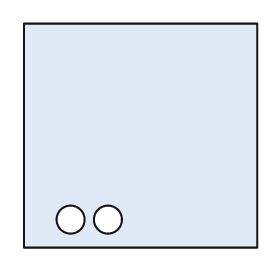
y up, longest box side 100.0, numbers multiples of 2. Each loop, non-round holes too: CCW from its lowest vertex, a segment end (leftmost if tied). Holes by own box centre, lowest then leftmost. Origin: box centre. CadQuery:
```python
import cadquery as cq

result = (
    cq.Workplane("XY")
    .moveTo(-50.0, -48.0)
    .lineTo(50.0, -48.0)
    .lineTo(50.0, 48.0)
    .lineTo(-50.0, 48.0)
    .close()
    .moveTo(-30.0, -36.0)
    .circle(6.0)
    .moveTo(-14.0, -36.0)
    .circle(6.0)
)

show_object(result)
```